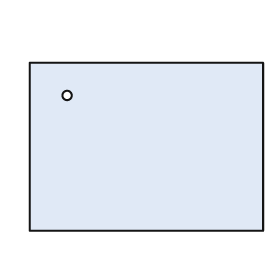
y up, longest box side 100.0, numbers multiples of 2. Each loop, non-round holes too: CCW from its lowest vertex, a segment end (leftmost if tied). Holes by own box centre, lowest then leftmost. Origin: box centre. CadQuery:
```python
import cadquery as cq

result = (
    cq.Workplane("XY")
    .moveTo(-50.0, -36.0)
    .lineTo(50.0, -36.0)
    .lineTo(50.0, 36.0)
    .lineTo(-50.0, 36.0)
    .close()
    .moveTo(-34.0, 22.0)
    .circle(2.0)
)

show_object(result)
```